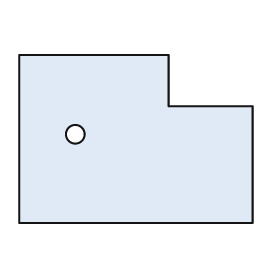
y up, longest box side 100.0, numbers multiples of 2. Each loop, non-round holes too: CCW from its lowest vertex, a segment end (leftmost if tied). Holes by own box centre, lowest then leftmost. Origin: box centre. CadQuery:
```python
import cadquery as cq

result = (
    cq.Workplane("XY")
    .moveTo(-50.0, -36.0)
    .lineTo(50.0, -36.0)
    .lineTo(50.0, 14.0)
    .lineTo(14.0, 14.0)
    .lineTo(14.0, 36.0)
    .lineTo(-50.0, 36.0)
    .close()
    .moveTo(-26.0, 2.0)
    .circle(4.0)
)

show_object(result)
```